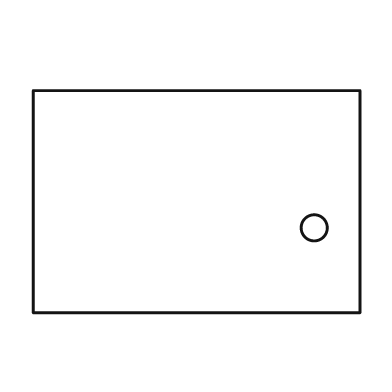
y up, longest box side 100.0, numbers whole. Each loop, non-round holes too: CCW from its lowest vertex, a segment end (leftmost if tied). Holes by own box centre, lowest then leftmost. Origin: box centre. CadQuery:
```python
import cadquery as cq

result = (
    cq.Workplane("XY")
    .moveTo(-50.0, -34.0)
    .lineTo(50.0, -34.0)
    .lineTo(50.0, 34.0)
    .lineTo(-50.0, 34.0)
    .close()
    .moveTo(36.0, -8.0)
    .circle(4.0)
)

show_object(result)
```